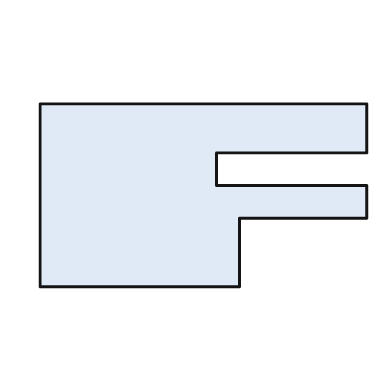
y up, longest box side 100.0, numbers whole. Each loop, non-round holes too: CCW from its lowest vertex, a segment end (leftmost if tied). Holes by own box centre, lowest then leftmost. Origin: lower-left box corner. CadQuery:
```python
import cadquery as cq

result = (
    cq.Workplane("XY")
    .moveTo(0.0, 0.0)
    .lineTo(61.0, 0.0)
    .lineTo(61.0, 21.0)
    .lineTo(100.0, 21.0)
    .lineTo(100.0, 31.0)
    .lineTo(54.0, 31.0)
    .lineTo(54.0, 41.0)
    .lineTo(100.0, 41.0)
    .lineTo(100.0, 56.0)
    .lineTo(0.0, 56.0)
    .close()
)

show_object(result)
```